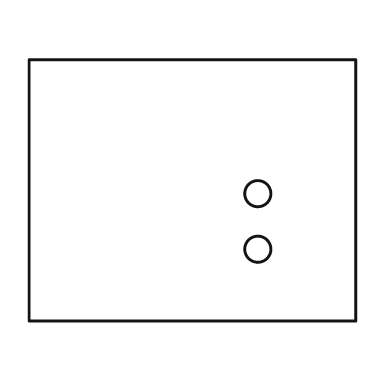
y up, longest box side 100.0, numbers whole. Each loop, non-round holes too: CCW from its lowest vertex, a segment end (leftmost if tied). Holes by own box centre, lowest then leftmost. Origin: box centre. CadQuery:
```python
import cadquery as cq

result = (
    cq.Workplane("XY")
    .moveTo(-50.0, -40.0)
    .lineTo(50.0, -40.0)
    .lineTo(50.0, 40.0)
    .lineTo(-50.0, 40.0)
    .close()
    .moveTo(20.0, -18.0)
    .circle(4.0)
    .moveTo(20.0, -1.0)
    .circle(4.0)
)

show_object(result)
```